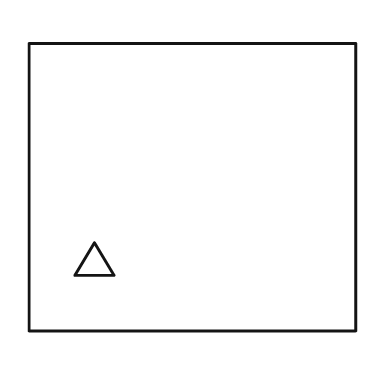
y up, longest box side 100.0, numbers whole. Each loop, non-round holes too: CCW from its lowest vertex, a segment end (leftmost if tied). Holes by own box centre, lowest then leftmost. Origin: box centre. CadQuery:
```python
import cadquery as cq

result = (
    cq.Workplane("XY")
    .moveTo(-50.0, -44.0)
    .lineTo(50.0, -44.0)
    .lineTo(50.0, 44.0)
    .lineTo(-50.0, 44.0)
    .close()
    .moveTo(-36.0, -27.0)
    .lineTo(-24.0, -27.0)
    .lineTo(-30.0, -17.0)
    .close()
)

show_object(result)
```